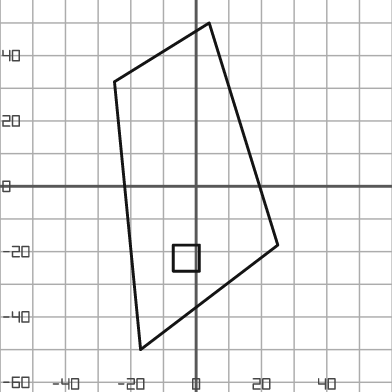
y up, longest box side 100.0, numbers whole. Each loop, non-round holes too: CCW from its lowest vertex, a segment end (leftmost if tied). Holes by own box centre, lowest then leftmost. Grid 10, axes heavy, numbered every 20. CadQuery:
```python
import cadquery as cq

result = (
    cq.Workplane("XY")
    .moveTo(-17.0, -50.0)
    .lineTo(25.0, -18.0)
    .lineTo(4.0, 50.0)
    .lineTo(-25.0, 32.0)
    .close()
    .moveTo(-7.0, -26.0)
    .lineTo(1.0, -26.0)
    .lineTo(1.0, -18.0)
    .lineTo(-7.0, -18.0)
    .close()
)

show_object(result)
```